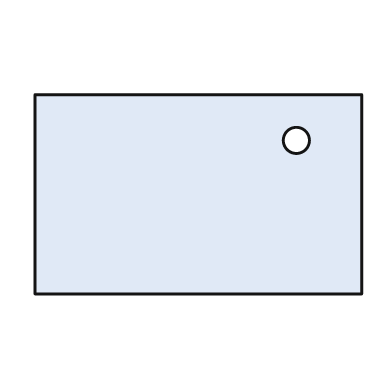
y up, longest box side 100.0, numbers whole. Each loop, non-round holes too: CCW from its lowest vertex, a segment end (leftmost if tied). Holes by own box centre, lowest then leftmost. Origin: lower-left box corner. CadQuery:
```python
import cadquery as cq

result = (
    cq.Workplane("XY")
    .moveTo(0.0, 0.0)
    .lineTo(100.0, 0.0)
    .lineTo(100.0, 61.0)
    .lineTo(0.0, 61.0)
    .close()
    .moveTo(80.0, 47.0)
    .circle(4.0)
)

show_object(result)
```